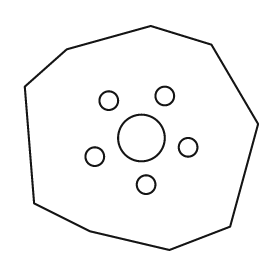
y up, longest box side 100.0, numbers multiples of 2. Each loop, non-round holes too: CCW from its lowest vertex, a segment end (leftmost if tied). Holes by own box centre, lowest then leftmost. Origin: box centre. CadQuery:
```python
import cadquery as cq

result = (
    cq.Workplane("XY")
    .moveTo(12.0, -48.0)
    .lineTo(38.0, -38.0)
    .lineTo(50.0, 6.0)
    .lineTo(30.0, 40.0)
    .lineTo(4.0, 48.0)
    .lineTo(-32.0, 38.0)
    .lineTo(-50.0, 22.0)
    .lineTo(-46.0, -28.0)
    .lineTo(-22.0, -40.0)
    .close()
    .moveTo(2.0, -20.0)
    .circle(4.0)
    .moveTo(-20.0, -8.0)
    .circle(4.0)
    .moveTo(20.0, -4.0)
    .circle(4.0)
    .moveTo(0.0, 0.0)
    .circle(10.0)
    .moveTo(-14.0, 16.0)
    .circle(4.0)
    .moveTo(10.0, 18.0)
    .circle(4.0)
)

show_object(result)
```